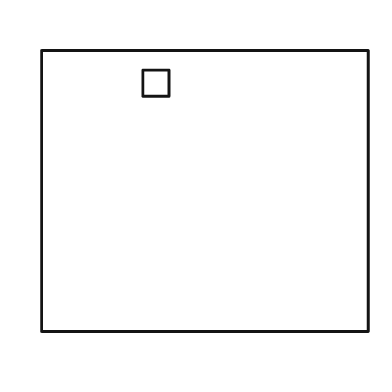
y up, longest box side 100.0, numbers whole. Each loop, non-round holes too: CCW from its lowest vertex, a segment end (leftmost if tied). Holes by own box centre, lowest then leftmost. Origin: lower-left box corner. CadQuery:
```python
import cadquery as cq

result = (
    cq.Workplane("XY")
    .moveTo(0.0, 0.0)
    .lineTo(100.0, 0.0)
    .lineTo(100.0, 86.0)
    .lineTo(0.0, 86.0)
    .close()
    .moveTo(31.0, 72.0)
    .lineTo(39.0, 72.0)
    .lineTo(39.0, 80.0)
    .lineTo(31.0, 80.0)
    .close()
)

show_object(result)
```